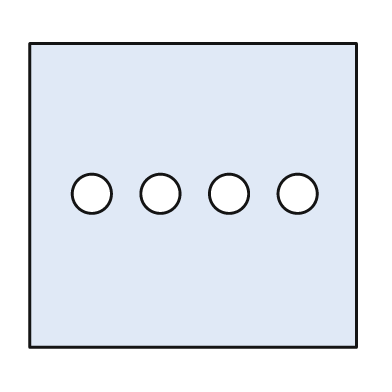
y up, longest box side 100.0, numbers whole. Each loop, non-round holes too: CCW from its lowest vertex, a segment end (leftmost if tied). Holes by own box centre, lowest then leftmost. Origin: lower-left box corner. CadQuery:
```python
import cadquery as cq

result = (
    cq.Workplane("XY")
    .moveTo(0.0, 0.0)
    .lineTo(100.0, 0.0)
    .lineTo(100.0, 93.0)
    .lineTo(0.0, 93.0)
    .close()
    .moveTo(19.0, 47.0)
    .circle(6.0)
    .moveTo(40.0, 47.0)
    .circle(6.0)
    .moveTo(61.0, 47.0)
    .circle(6.0)
    .moveTo(82.0, 47.0)
    .circle(6.0)
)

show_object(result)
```